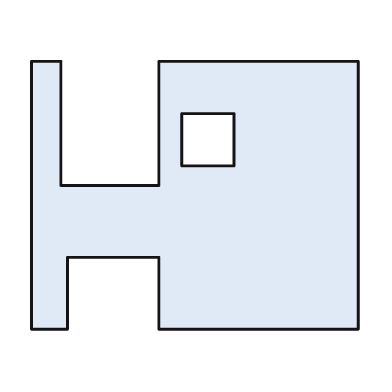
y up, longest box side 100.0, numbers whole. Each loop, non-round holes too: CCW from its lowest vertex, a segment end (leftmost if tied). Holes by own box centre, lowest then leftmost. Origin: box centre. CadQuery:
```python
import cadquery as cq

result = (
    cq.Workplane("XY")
    .moveTo(-50.0, -41.0)
    .lineTo(-39.0, -41.0)
    .lineTo(-39.0, -19.0)
    .lineTo(-11.0, -19.0)
    .lineTo(-11.0, -41.0)
    .lineTo(50.0, -41.0)
    .lineTo(50.0, 41.0)
    .lineTo(-11.0, 41.0)
    .lineTo(-11.0, 3.0)
    .lineTo(-41.0, 3.0)
    .lineTo(-41.0, 41.0)
    .lineTo(-50.0, 41.0)
    .close()
    .moveTo(-4.0, 9.0)
    .lineTo(12.0, 9.0)
    .lineTo(12.0, 25.0)
    .lineTo(-4.0, 25.0)
    .close()
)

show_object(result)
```